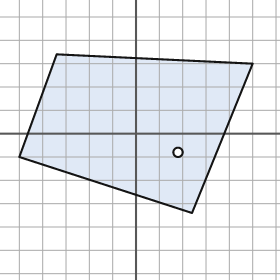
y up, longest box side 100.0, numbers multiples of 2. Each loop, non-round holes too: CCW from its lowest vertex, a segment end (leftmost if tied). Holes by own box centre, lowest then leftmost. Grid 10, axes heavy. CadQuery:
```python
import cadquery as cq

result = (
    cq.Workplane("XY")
    .moveTo(24.0, -34.0)
    .lineTo(50.0, 30.0)
    .lineTo(-34.0, 34.0)
    .lineTo(-50.0, -10.0)
    .close()
    .moveTo(18.0, -8.0)
    .circle(2.0)
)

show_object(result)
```